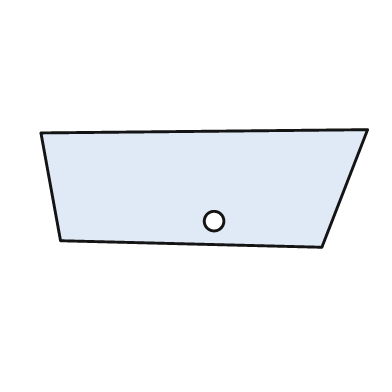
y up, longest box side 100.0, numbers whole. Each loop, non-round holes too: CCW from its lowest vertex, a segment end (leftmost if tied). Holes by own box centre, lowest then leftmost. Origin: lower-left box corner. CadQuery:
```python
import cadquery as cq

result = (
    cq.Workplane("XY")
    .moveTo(86.0, 0.0)
    .lineTo(100.0, 36.0)
    .lineTo(0.0, 35.0)
    .lineTo(6.0, 2.0)
    .close()
    .moveTo(53.0, 8.0)
    .circle(3.0)
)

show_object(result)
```